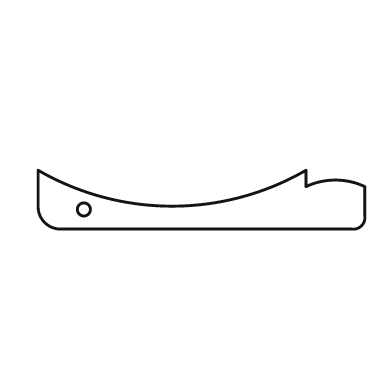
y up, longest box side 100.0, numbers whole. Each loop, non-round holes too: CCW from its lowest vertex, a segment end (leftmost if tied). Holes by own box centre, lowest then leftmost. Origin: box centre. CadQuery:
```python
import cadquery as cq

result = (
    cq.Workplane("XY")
    .moveTo(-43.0, -9.0)
    .lineTo(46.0, -9.0)
    .threePointArc((49.0, -8.0), (50.0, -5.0))
    .lineTo(50.0, 4.0)
    .threePointArc((41.0, 6.0), (32.0, 4.0))
    .lineTo(32.0, 9.0)
    .threePointArc((-9.0, -2.0), (-50.0, 9.0))
    .lineTo(-50.0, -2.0)
    .threePointArc((-48.0, -7.0), (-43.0, -9.0))
    .close()
    .moveTo(-36.0, -3.0)
    .circle(2.0)
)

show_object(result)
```